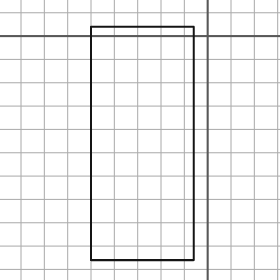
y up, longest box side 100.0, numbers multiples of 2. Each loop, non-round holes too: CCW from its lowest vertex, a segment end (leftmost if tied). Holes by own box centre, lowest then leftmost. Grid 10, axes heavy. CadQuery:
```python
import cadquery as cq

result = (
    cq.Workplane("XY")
    .moveTo(-50.0, -96.0)
    .lineTo(-6.0, -96.0)
    .lineTo(-6.0, 4.0)
    .lineTo(-50.0, 4.0)
    .close()
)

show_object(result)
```